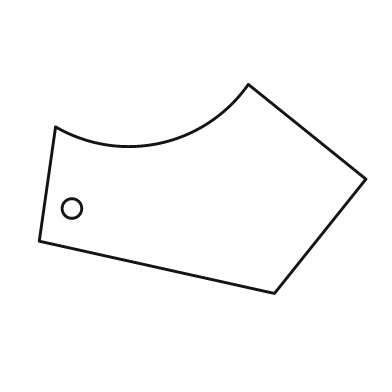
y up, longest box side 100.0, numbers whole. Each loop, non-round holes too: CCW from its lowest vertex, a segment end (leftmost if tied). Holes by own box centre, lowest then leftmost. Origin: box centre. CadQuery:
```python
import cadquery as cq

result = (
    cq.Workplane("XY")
    .moveTo(22.0, -32.0)
    .lineTo(50.0, 3.0)
    .lineTo(14.0, 32.0)
    .threePointArc((-13.0, 14.0), (-45.0, 19.0))
    .lineTo(-50.0, -16.0)
    .close()
    .moveTo(-40.0, -6.0)
    .circle(3.0)
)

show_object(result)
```